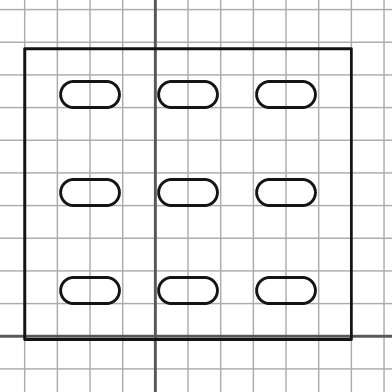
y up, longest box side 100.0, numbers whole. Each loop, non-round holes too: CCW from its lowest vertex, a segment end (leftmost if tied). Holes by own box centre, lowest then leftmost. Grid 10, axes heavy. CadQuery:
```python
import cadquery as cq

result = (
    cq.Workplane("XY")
    .moveTo(-40.0, -1.0)
    .lineTo(60.0, -1.0)
    .lineTo(60.0, 88.0)
    .lineTo(-40.0, 88.0)
    .close()
    .moveTo(-25.0, 10.0)
    .lineTo(-15.0, 10.0)
    .threePointArc((-11.0, 14.0), (-15.0, 18.0))
    .lineTo(-25.0, 18.0)
    .threePointArc((-29.0, 14.0), (-25.0, 10.0))
    .close()
    .moveTo(5.0, 10.0)
    .lineTo(15.0, 10.0)
    .threePointArc((19.0, 14.0), (15.0, 18.0))
    .lineTo(5.0, 18.0)
    .threePointArc((1.0, 14.0), (5.0, 10.0))
    .close()
    .moveTo(35.0, 10.0)
    .lineTo(45.0, 10.0)
    .threePointArc((49.0, 14.0), (45.0, 18.0))
    .lineTo(35.0, 18.0)
    .threePointArc((31.0, 14.0), (35.0, 10.0))
    .close()
    .moveTo(-25.0, 40.0)
    .lineTo(-15.0, 40.0)
    .threePointArc((-11.0, 44.0), (-15.0, 48.0))
    .lineTo(-25.0, 48.0)
    .threePointArc((-29.0, 44.0), (-25.0, 40.0))
    .close()
    .moveTo(5.0, 40.0)
    .lineTo(15.0, 40.0)
    .threePointArc((19.0, 44.0), (15.0, 48.0))
    .lineTo(5.0, 48.0)
    .threePointArc((1.0, 44.0), (5.0, 40.0))
    .close()
    .moveTo(35.0, 40.0)
    .lineTo(45.0, 40.0)
    .threePointArc((49.0, 44.0), (45.0, 48.0))
    .lineTo(35.0, 48.0)
    .threePointArc((31.0, 44.0), (35.0, 40.0))
    .close()
    .moveTo(-25.0, 70.0)
    .lineTo(-15.0, 70.0)
    .threePointArc((-11.0, 74.0), (-15.0, 78.0))
    .lineTo(-25.0, 78.0)
    .threePointArc((-29.0, 74.0), (-25.0, 70.0))
    .close()
    .moveTo(5.0, 70.0)
    .lineTo(15.0, 70.0)
    .threePointArc((19.0, 74.0), (15.0, 78.0))
    .lineTo(5.0, 78.0)
    .threePointArc((1.0, 74.0), (5.0, 70.0))
    .close()
    .moveTo(35.0, 70.0)
    .lineTo(45.0, 70.0)
    .threePointArc((49.0, 74.0), (45.0, 78.0))
    .lineTo(35.0, 78.0)
    .threePointArc((31.0, 74.0), (35.0, 70.0))
    .close()
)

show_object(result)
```